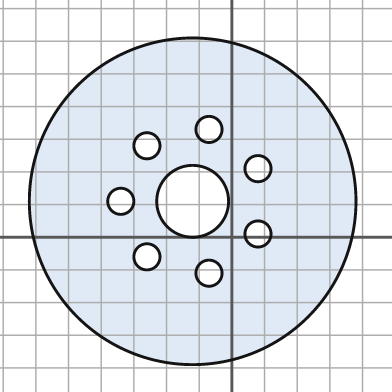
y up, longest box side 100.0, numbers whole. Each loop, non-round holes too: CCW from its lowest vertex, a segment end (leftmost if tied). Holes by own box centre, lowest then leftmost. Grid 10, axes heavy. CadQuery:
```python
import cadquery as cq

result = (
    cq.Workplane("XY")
    .moveTo(-12.0, 11.0)
    .circle(50.0)
    .moveTo(-7.0, -11.0)
    .circle(4.0)
    .moveTo(-26.0, -6.0)
    .circle(4.0)
    .moveTo(8.0, 1.0)
    .circle(4.0)
    .moveTo(-34.0, 11.0)
    .circle(4.0)
    .moveTo(-12.0, 11.0)
    .circle(11.0)
    .moveTo(8.0, 21.0)
    .circle(4.0)
    .moveTo(-26.0, 28.0)
    .circle(4.0)
    .moveTo(-7.0, 33.0)
    .circle(4.0)
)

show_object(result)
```